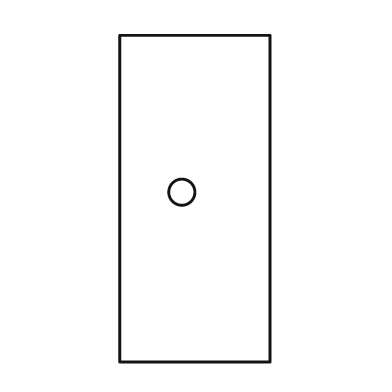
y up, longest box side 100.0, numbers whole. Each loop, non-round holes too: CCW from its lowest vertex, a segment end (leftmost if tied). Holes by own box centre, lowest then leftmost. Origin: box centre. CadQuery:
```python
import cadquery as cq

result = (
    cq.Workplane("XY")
    .moveTo(-23.0, -50.0)
    .lineTo(23.0, -50.0)
    .lineTo(23.0, 50.0)
    .lineTo(-23.0, 50.0)
    .close()
    .moveTo(-4.0, 2.0)
    .circle(4.0)
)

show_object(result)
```